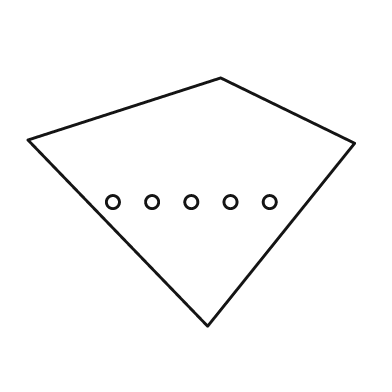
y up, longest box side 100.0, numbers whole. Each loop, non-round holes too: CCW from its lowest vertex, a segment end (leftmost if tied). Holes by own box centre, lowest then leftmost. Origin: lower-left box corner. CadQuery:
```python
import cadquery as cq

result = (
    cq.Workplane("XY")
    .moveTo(55.0, 0.0)
    .lineTo(100.0, 56.0)
    .lineTo(59.0, 76.0)
    .lineTo(0.0, 57.0)
    .close()
    .moveTo(26.0, 38.0)
    .circle(2.0)
    .moveTo(38.0, 38.0)
    .circle(2.0)
    .moveTo(50.0, 38.0)
    .circle(2.0)
    .moveTo(62.0, 38.0)
    .circle(2.0)
    .moveTo(74.0, 38.0)
    .circle(2.0)
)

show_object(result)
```